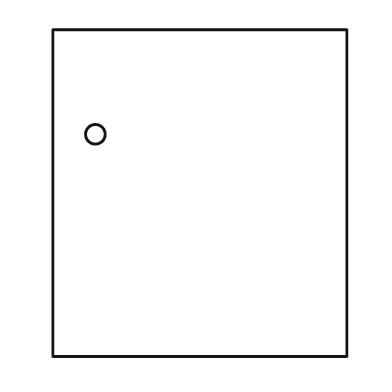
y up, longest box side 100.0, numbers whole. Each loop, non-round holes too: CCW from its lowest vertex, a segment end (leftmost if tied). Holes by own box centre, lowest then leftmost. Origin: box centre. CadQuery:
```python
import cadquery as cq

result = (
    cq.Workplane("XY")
    .moveTo(-45.0, -50.0)
    .lineTo(45.0, -50.0)
    .lineTo(45.0, 50.0)
    .lineTo(-45.0, 50.0)
    .close()
    .moveTo(-32.0, 18.0)
    .circle(3.0)
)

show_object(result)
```